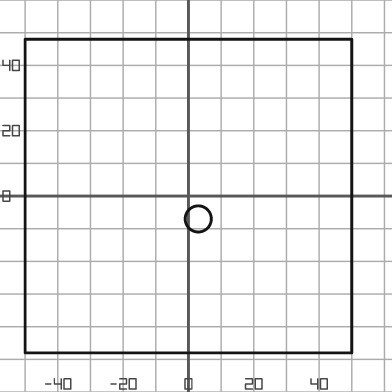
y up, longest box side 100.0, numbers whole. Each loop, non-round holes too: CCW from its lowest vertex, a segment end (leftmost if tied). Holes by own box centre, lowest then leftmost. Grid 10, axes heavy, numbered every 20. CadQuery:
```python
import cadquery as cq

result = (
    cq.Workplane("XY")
    .moveTo(-50.0, -48.0)
    .lineTo(50.0, -48.0)
    .lineTo(50.0, 48.0)
    .lineTo(-50.0, 48.0)
    .close()
    .moveTo(3.0, -7.0)
    .circle(4.0)
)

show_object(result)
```